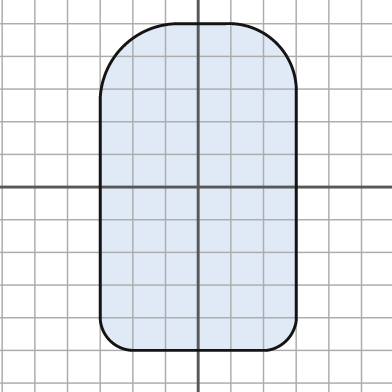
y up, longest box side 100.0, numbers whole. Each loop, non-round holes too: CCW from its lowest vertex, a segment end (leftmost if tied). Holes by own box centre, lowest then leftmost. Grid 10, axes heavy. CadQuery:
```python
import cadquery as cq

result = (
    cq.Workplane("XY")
    .moveTo(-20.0, -50.0)
    .lineTo(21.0, -50.0)
    .threePointArc((27.0, -47.0), (30.0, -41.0))
    .lineTo(30.0, 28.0)
    .threePointArc((24.0, 44.0), (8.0, 50.0))
    .lineTo(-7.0, 50.0)
    .threePointArc((-23.0, 43.0), (-30.0, 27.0))
    .lineTo(-30.0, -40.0)
    .threePointArc((-27.0, -47.0), (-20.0, -50.0))
    .close()
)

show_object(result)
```